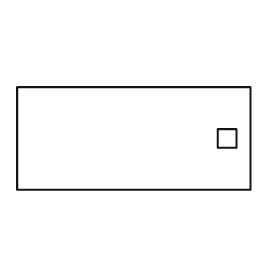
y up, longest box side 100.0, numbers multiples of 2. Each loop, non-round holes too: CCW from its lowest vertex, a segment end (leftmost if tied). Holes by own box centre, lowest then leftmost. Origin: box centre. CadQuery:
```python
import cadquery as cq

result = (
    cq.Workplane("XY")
    .moveTo(-50.0, -22.0)
    .lineTo(50.0, -22.0)
    .lineTo(50.0, 22.0)
    .lineTo(-50.0, 22.0)
    .close()
    .moveTo(36.0, -4.0)
    .lineTo(44.0, -4.0)
    .lineTo(44.0, 4.0)
    .lineTo(36.0, 4.0)
    .close()
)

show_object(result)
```